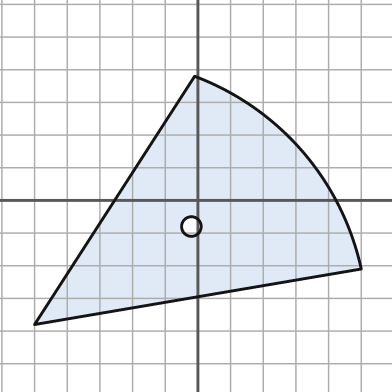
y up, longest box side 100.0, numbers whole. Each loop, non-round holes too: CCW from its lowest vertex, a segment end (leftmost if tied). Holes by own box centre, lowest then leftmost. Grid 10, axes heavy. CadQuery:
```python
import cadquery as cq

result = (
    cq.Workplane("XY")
    .moveTo(-50.0, -38.0)
    .lineTo(50.0, -21.0)
    .threePointArc((32.0, 15.0), (-1.0, 38.0))
    .close()
    .moveTo(-2.0, -8.0)
    .circle(3.0)
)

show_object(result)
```